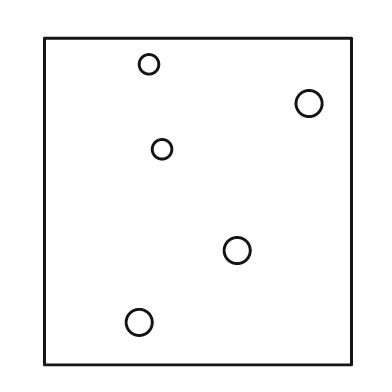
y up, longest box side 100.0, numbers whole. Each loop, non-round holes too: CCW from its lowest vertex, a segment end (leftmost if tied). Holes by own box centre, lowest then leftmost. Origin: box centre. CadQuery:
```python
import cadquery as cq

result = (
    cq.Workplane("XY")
    .moveTo(-47.0, -50.0)
    .lineTo(47.0, -50.0)
    .lineTo(47.0, 50.0)
    .lineTo(-47.0, 50.0)
    .close()
    .moveTo(-18.0, -37.0)
    .circle(4.0)
    .moveTo(12.0, -15.0)
    .circle(4.0)
    .moveTo(-11.0, 16.0)
    .circle(3.0)
    .moveTo(34.0, 30.0)
    .circle(4.0)
    .moveTo(-15.0, 42.0)
    .circle(3.0)
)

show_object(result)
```